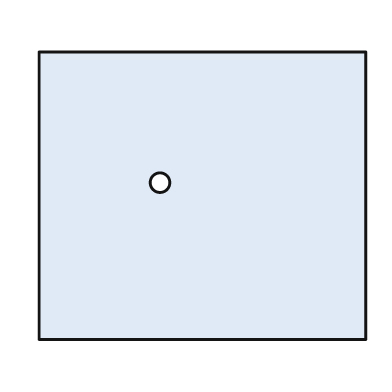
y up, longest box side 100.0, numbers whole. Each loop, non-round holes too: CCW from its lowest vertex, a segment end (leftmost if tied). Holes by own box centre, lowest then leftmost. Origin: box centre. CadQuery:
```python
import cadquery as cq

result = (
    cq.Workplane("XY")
    .moveTo(-50.0, -44.0)
    .lineTo(50.0, -44.0)
    .lineTo(50.0, 44.0)
    .lineTo(-50.0, 44.0)
    .close()
    .moveTo(-13.0, 4.0)
    .circle(3.0)
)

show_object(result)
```